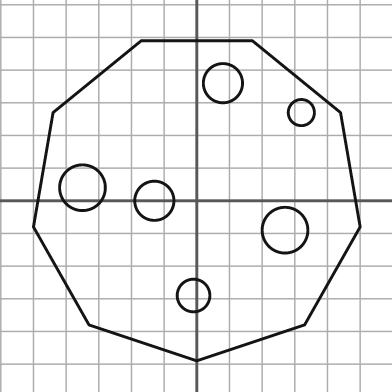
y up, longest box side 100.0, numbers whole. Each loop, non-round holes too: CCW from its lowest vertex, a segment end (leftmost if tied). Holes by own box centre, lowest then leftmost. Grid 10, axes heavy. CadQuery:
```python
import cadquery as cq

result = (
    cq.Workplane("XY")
    .moveTo(0.0, -49.0)
    .lineTo(33.0, -38.0)
    .lineTo(50.0, -8.0)
    .lineTo(44.0, 27.0)
    .lineTo(17.0, 49.0)
    .lineTo(-17.0, 49.0)
    .lineTo(-44.0, 27.0)
    .lineTo(-50.0, -8.0)
    .lineTo(-33.0, -38.0)
    .close()
    .moveTo(-1.0, -29.0)
    .circle(5.0)
    .moveTo(27.0, -9.0)
    .circle(7.0)
    .moveTo(-13.0, 0.0)
    .circle(6.0)
    .moveTo(-35.0, 4.0)
    .circle(7.0)
    .moveTo(32.0, 27.0)
    .circle(4.0)
    .moveTo(8.0, 36.0)
    .circle(6.0)
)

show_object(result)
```